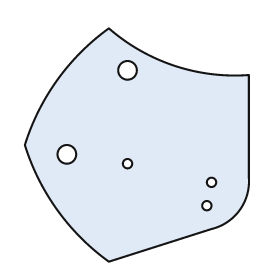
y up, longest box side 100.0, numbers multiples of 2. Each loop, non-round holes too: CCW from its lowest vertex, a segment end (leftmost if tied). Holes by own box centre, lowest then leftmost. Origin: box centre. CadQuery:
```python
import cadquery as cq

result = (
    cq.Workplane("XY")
    .moveTo(-12.0, -50.0)
    .lineTo(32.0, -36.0)
    .threePointArc((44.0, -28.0), (48.0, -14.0))
    .lineTo(48.0, 30.0)
    .threePointArc((16.0, 34.0), (-12.0, 50.0))
    .threePointArc((-34.0, 28.0), (-48.0, 0.0))
    .threePointArc((-34.0, -28.0), (-12.0, -50.0))
    .close()
    .moveTo(30.0, -26.0)
    .circle(2.0)
    .moveTo(32.0, -16.0)
    .circle(2.0)
    .moveTo(-4.0, -8.0)
    .circle(2.0)
    .moveTo(-30.0, -4.0)
    .circle(4.0)
    .moveTo(-4.0, 32.0)
    .circle(4.0)
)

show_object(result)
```